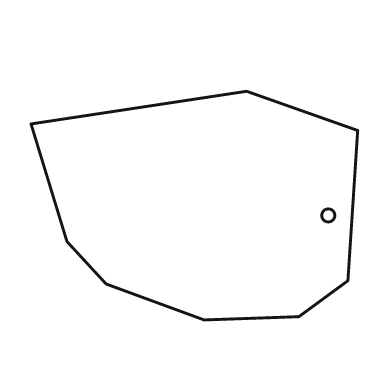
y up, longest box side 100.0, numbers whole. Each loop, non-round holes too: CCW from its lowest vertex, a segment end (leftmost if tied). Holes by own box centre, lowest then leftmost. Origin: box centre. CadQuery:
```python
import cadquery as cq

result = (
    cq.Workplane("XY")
    .moveTo(3.0, -35.0)
    .lineTo(32.0, -34.0)
    .lineTo(47.0, -23.0)
    .lineTo(50.0, 23.0)
    .lineTo(16.0, 35.0)
    .lineTo(-50.0, 25.0)
    .lineTo(-39.0, -11.0)
    .lineTo(-27.0, -24.0)
    .close()
    .moveTo(41.0, -3.0)
    .circle(2.0)
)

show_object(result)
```